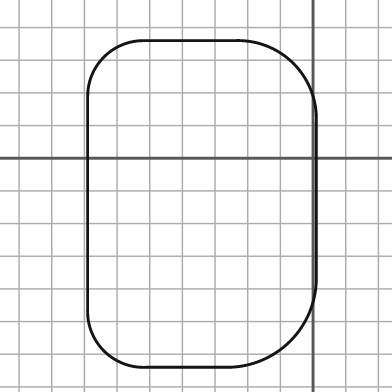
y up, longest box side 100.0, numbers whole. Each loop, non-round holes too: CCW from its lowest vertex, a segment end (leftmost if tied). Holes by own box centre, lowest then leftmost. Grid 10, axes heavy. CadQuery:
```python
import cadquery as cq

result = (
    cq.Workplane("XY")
    .moveTo(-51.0, -64.0)
    .lineTo(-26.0, -64.0)
    .threePointArc((-7.0, -56.0), (1.0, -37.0))
    .lineTo(1.0, 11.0)
    .threePointArc((-6.0, 29.0), (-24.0, 36.0))
    .lineTo(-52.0, 36.0)
    .threePointArc((-64.0, 31.0), (-69.0, 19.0))
    .lineTo(-69.0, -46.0)
    .threePointArc((-64.0, -59.0), (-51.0, -64.0))
    .close()
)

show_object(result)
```